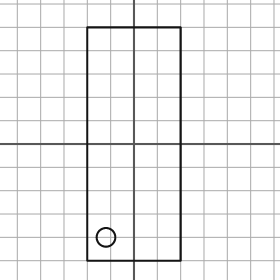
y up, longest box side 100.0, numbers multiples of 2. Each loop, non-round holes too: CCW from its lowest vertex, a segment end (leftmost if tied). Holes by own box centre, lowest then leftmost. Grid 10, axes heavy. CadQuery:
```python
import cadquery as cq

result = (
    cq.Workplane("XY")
    .moveTo(-20.0, -50.0)
    .lineTo(20.0, -50.0)
    .lineTo(20.0, 50.0)
    .lineTo(-20.0, 50.0)
    .close()
    .moveTo(-12.0, -40.0)
    .circle(4.0)
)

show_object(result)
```